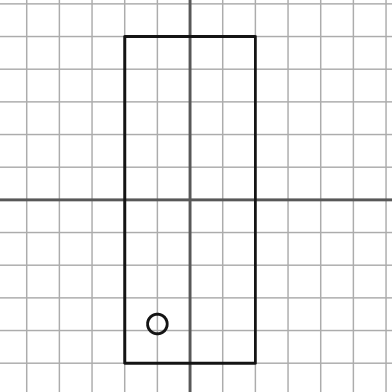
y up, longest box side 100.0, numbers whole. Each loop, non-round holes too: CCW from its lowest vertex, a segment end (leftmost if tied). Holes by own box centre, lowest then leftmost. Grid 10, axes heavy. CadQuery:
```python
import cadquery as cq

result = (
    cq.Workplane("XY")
    .moveTo(-20.0, -50.0)
    .lineTo(20.0, -50.0)
    .lineTo(20.0, 50.0)
    .lineTo(-20.0, 50.0)
    .close()
    .moveTo(-10.0, -38.0)
    .circle(3.0)
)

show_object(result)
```